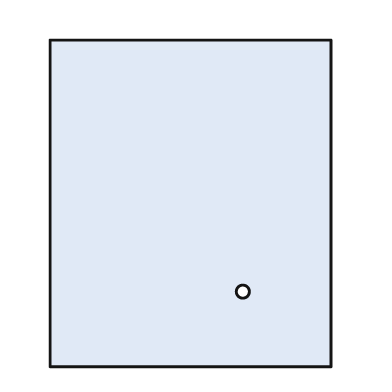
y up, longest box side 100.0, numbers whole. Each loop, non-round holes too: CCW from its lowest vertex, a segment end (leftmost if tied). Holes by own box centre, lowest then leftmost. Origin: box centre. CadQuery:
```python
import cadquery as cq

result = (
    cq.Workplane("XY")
    .moveTo(-43.0, -50.0)
    .lineTo(43.0, -50.0)
    .lineTo(43.0, 50.0)
    .lineTo(-43.0, 50.0)
    .close()
    .moveTo(16.0, -27.0)
    .circle(2.0)
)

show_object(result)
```